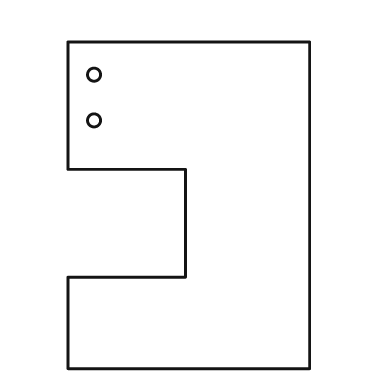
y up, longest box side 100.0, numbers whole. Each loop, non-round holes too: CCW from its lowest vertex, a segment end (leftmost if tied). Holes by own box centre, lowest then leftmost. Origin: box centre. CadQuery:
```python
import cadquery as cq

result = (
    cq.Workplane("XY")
    .moveTo(-37.0, -50.0)
    .lineTo(37.0, -50.0)
    .lineTo(37.0, 50.0)
    .lineTo(-37.0, 50.0)
    .lineTo(-37.0, 11.0)
    .lineTo(-1.0, 11.0)
    .lineTo(-1.0, -22.0)
    .lineTo(-37.0, -22.0)
    .close()
    .moveTo(-29.0, 26.0)
    .circle(2.0)
    .moveTo(-29.0, 40.0)
    .circle(2.0)
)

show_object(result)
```